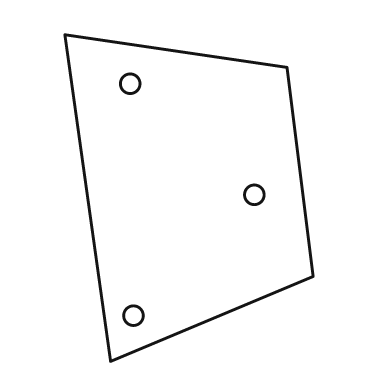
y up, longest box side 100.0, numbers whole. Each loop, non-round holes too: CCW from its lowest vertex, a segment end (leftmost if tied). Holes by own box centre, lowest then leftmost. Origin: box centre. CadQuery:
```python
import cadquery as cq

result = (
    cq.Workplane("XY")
    .moveTo(-24.0, -50.0)
    .lineTo(38.0, -24.0)
    .lineTo(30.0, 40.0)
    .lineTo(-38.0, 50.0)
    .close()
    .moveTo(-17.0, -36.0)
    .circle(3.0)
    .moveTo(20.0, 1.0)
    .circle(3.0)
    .moveTo(-18.0, 35.0)
    .circle(3.0)
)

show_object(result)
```